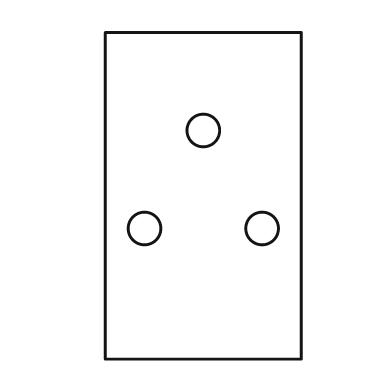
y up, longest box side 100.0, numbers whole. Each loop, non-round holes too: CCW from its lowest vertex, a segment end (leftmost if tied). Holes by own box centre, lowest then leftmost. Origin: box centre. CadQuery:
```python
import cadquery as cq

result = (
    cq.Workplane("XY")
    .moveTo(-30.0, -50.0)
    .lineTo(30.0, -50.0)
    .lineTo(30.0, 50.0)
    .lineTo(-30.0, 50.0)
    .close()
    .moveTo(-18.0, -10.0)
    .circle(5.0)
    .moveTo(18.0, -10.0)
    .circle(5.0)
    .moveTo(0.0, 20.0)
    .circle(5.0)
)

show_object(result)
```